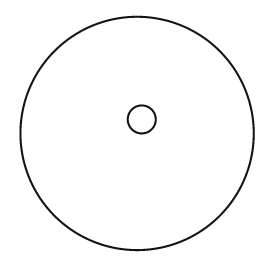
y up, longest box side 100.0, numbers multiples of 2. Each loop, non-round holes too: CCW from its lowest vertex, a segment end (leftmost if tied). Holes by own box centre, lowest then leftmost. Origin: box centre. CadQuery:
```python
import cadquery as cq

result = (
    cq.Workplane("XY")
    .moveTo(0.0, 0.0)
    .circle(50.0)
    .moveTo(2.0, 6.0)
    .circle(6.0)
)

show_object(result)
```